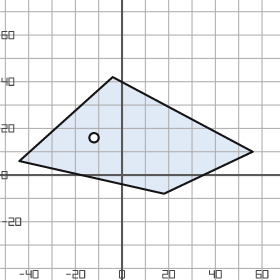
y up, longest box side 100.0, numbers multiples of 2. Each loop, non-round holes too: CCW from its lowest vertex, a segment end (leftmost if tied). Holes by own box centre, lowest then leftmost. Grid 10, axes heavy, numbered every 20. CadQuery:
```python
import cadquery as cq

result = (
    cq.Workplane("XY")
    .moveTo(18.0, -8.0)
    .lineTo(56.0, 10.0)
    .lineTo(-4.0, 42.0)
    .lineTo(-44.0, 6.0)
    .close()
    .moveTo(-12.0, 16.0)
    .circle(2.0)
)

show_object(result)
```